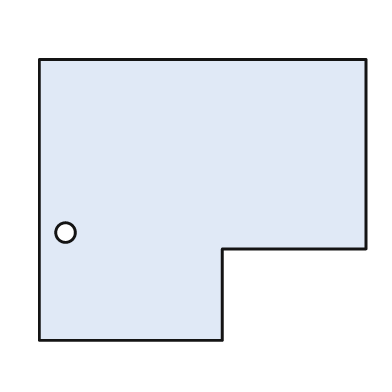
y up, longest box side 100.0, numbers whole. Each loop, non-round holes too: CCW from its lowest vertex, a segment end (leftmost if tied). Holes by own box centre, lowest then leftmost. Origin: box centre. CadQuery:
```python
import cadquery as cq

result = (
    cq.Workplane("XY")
    .moveTo(-50.0, -43.0)
    .lineTo(6.0, -43.0)
    .lineTo(6.0, -15.0)
    .lineTo(50.0, -15.0)
    .lineTo(50.0, 43.0)
    .lineTo(-50.0, 43.0)
    .close()
    .moveTo(-42.0, -10.0)
    .circle(3.0)
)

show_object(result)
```